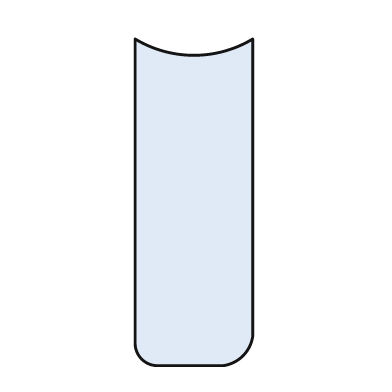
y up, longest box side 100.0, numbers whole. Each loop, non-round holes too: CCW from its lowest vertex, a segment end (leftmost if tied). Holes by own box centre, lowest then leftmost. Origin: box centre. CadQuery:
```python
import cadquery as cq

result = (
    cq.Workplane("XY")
    .moveTo(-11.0, -50.0)
    .lineTo(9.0, -50.0)
    .threePointArc((15.0, -47.0), (18.0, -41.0))
    .lineTo(18.0, 50.0)
    .threePointArc((0.0, 45.0), (-18.0, 50.0))
    .lineTo(-18.0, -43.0)
    .threePointArc((-16.0, -48.0), (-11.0, -50.0))
    .close()
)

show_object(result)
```